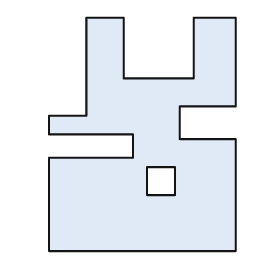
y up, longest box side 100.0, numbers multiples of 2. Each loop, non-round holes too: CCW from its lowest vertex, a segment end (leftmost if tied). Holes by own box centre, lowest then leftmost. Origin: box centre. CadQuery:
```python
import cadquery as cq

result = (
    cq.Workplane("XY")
    .moveTo(-40.0, -50.0)
    .lineTo(40.0, -50.0)
    .lineTo(40.0, -2.0)
    .lineTo(16.0, -2.0)
    .lineTo(16.0, 12.0)
    .lineTo(40.0, 12.0)
    .lineTo(40.0, 50.0)
    .lineTo(22.0, 50.0)
    .lineTo(22.0, 24.0)
    .lineTo(-8.0, 24.0)
    .lineTo(-8.0, 50.0)
    .lineTo(-24.0, 50.0)
    .lineTo(-24.0, 8.0)
    .lineTo(-40.0, 8.0)
    .lineTo(-40.0, 0.0)
    .lineTo(-4.0, 0.0)
    .lineTo(-4.0, -10.0)
    .lineTo(-40.0, -10.0)
    .close()
    .moveTo(2.0, -26.0)
    .lineTo(14.0, -26.0)
    .lineTo(14.0, -14.0)
    .lineTo(2.0, -14.0)
    .close()
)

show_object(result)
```